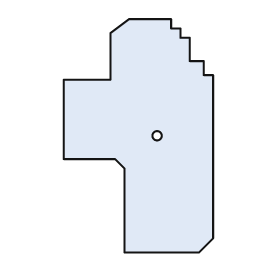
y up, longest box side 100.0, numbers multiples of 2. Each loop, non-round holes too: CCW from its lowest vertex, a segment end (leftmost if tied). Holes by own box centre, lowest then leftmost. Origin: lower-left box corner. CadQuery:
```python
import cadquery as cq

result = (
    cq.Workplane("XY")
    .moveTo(26.0, 0.0)
    .lineTo(58.0, 0.0)
    .lineTo(64.0, 6.0)
    .lineTo(64.0, 76.0)
    .lineTo(60.0, 76.0)
    .lineTo(60.0, 82.0)
    .lineTo(54.0, 82.0)
    .lineTo(54.0, 92.0)
    .lineTo(50.0, 92.0)
    .lineTo(50.0, 96.0)
    .lineTo(46.0, 96.0)
    .lineTo(46.0, 100.0)
    .lineTo(28.0, 100.0)
    .lineTo(20.0, 94.0)
    .lineTo(20.0, 74.0)
    .lineTo(0.0, 74.0)
    .lineTo(0.0, 40.0)
    .lineTo(22.0, 40.0)
    .lineTo(26.0, 36.0)
    .close()
    .moveTo(40.0, 50.0)
    .circle(2.0)
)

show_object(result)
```